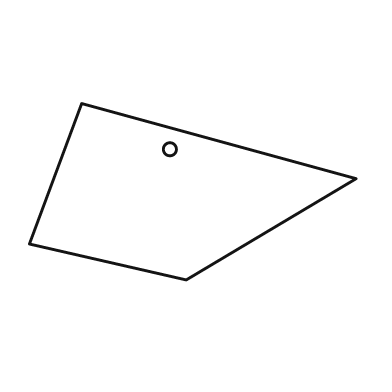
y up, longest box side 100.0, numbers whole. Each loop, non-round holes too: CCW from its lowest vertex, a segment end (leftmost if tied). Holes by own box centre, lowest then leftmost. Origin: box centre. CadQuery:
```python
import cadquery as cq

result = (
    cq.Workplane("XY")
    .moveTo(-2.0, -27.0)
    .lineTo(50.0, 4.0)
    .lineTo(-34.0, 27.0)
    .lineTo(-50.0, -16.0)
    .close()
    .moveTo(-7.0, 13.0)
    .circle(2.0)
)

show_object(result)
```